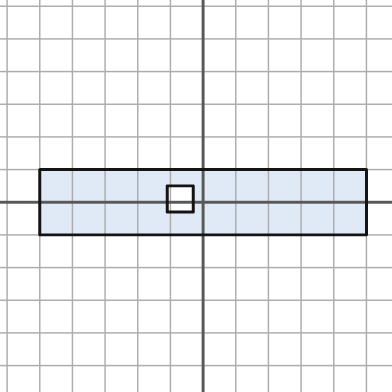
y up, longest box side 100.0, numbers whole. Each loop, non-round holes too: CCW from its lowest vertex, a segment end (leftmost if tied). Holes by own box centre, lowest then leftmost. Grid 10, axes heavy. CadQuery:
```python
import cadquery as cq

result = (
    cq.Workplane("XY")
    .moveTo(-50.0, -10.0)
    .lineTo(50.0, -10.0)
    .lineTo(50.0, 10.0)
    .lineTo(-50.0, 10.0)
    .close()
    .moveTo(-11.0, -3.0)
    .lineTo(-3.0, -3.0)
    .lineTo(-3.0, 5.0)
    .lineTo(-11.0, 5.0)
    .close()
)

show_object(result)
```